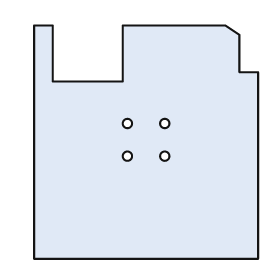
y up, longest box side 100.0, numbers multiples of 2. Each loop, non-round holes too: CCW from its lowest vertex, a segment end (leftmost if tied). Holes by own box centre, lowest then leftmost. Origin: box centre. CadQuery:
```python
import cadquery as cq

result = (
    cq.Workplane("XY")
    .moveTo(-48.0, -50.0)
    .lineTo(48.0, -50.0)
    .lineTo(48.0, 30.0)
    .lineTo(40.0, 30.0)
    .lineTo(40.0, 46.0)
    .lineTo(34.0, 50.0)
    .lineTo(-10.0, 50.0)
    .lineTo(-10.0, 26.0)
    .lineTo(-40.0, 26.0)
    .lineTo(-40.0, 50.0)
    .lineTo(-48.0, 50.0)
    .close()
    .moveTo(-8.0, -6.0)
    .circle(2.0)
    .moveTo(8.0, -6.0)
    .circle(2.0)
    .moveTo(-8.0, 8.0)
    .circle(2.0)
    .moveTo(8.0, 8.0)
    .circle(2.0)
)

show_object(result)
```